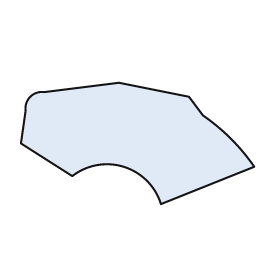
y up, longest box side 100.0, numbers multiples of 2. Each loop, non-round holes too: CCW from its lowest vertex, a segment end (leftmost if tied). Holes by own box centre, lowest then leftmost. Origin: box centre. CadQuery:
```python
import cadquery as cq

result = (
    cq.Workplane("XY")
    .moveTo(10.0, -26.0)
    .lineTo(50.0, -10.0)
    .threePointArc((40.0, 2.0), (28.0, 12.0))
    .lineTo(22.0, 20.0)
    .lineTo(-8.0, 26.0)
    .lineTo(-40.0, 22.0)
    .threePointArc((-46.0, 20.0), (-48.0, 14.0))
    .lineTo(-50.0, 0.0)
    .lineTo(-28.0, -14.0)
    .threePointArc((-6.0, -10.0), (10.0, -26.0))
    .close()
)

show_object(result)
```